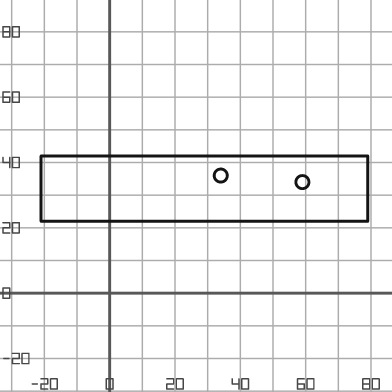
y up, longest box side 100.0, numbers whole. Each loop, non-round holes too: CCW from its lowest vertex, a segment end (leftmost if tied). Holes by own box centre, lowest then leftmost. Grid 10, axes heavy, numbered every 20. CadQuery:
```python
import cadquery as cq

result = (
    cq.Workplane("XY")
    .moveTo(-21.0, 22.0)
    .lineTo(79.0, 22.0)
    .lineTo(79.0, 42.0)
    .lineTo(-21.0, 42.0)
    .close()
    .moveTo(59.0, 34.0)
    .circle(2.0)
    .moveTo(34.0, 36.0)
    .circle(2.0)
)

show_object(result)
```